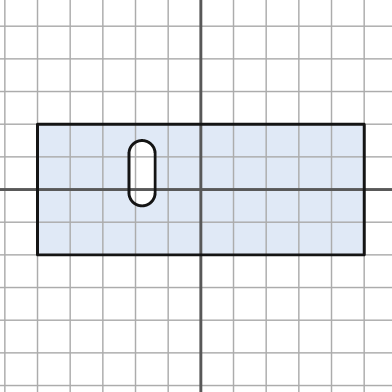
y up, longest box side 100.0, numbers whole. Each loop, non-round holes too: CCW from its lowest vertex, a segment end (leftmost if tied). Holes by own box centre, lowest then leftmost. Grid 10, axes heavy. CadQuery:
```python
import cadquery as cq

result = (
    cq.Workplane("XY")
    .moveTo(-50.0, -20.0)
    .lineTo(50.0, -20.0)
    .lineTo(50.0, 20.0)
    .lineTo(-50.0, 20.0)
    .close()
    .moveTo(-22.0, -1.0)
    .threePointArc((-18.0, -5.0), (-14.0, -1.0))
    .lineTo(-14.0, 11.0)
    .threePointArc((-18.0, 15.0), (-22.0, 11.0))
    .close()
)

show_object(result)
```